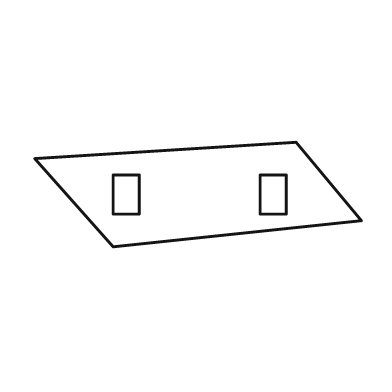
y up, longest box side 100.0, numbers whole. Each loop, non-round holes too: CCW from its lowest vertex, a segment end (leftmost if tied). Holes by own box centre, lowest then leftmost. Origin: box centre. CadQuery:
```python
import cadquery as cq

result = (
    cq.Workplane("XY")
    .moveTo(-26.0, -16.0)
    .lineTo(50.0, -8.0)
    .lineTo(30.0, 16.0)
    .lineTo(-50.0, 11.0)
    .close()
    .moveTo(-26.0, -6.0)
    .lineTo(-18.0, -6.0)
    .lineTo(-18.0, 6.0)
    .lineTo(-26.0, 6.0)
    .close()
    .moveTo(19.0, -6.0)
    .lineTo(27.0, -6.0)
    .lineTo(27.0, 6.0)
    .lineTo(19.0, 6.0)
    .close()
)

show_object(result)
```